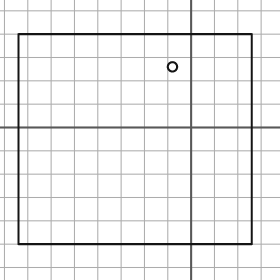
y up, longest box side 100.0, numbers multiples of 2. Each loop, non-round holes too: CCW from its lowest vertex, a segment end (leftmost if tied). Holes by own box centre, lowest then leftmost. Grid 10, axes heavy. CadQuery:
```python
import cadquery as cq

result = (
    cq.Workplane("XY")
    .moveTo(-74.0, -50.0)
    .lineTo(26.0, -50.0)
    .lineTo(26.0, 40.0)
    .lineTo(-74.0, 40.0)
    .close()
    .moveTo(-8.0, 26.0)
    .circle(2.0)
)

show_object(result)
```